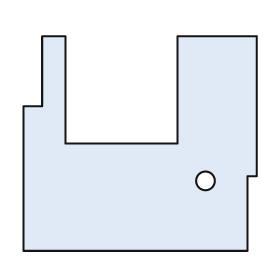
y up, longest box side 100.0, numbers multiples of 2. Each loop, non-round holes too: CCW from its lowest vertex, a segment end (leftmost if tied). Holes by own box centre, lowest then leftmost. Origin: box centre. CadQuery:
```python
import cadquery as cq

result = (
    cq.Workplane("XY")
    .moveTo(-50.0, -46.0)
    .lineTo(46.0, -46.0)
    .lineTo(46.0, -14.0)
    .lineTo(50.0, -14.0)
    .lineTo(50.0, 46.0)
    .lineTo(16.0, 46.0)
    .lineTo(16.0, 0.0)
    .lineTo(-32.0, 0.0)
    .lineTo(-32.0, 46.0)
    .lineTo(-42.0, 46.0)
    .lineTo(-42.0, 16.0)
    .lineTo(-50.0, 16.0)
    .close()
    .moveTo(28.0, -16.0)
    .circle(4.0)
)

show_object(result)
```